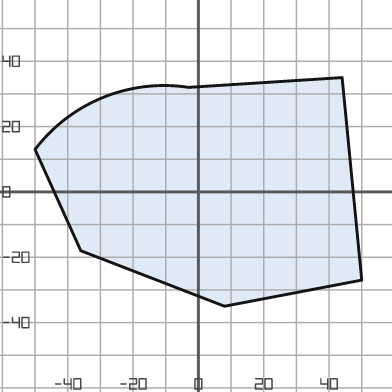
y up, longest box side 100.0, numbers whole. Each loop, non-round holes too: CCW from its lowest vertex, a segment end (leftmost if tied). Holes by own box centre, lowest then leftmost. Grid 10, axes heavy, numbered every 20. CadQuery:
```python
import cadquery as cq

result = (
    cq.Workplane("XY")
    .moveTo(8.0, -35.0)
    .lineTo(50.0, -27.0)
    .lineTo(44.0, 35.0)
    .lineTo(-3.0, 32.0)
    .threePointArc((-29.0, 29.0), (-50.0, 13.0))
    .lineTo(-36.0, -18.0)
    .close()
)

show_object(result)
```